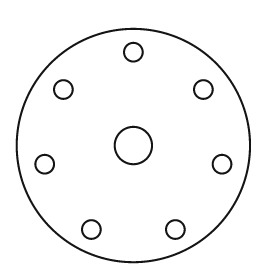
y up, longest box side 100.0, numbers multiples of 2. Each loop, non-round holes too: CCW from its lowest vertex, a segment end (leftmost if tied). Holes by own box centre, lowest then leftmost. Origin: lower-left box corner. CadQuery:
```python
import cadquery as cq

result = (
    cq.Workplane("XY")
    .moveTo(50.0, 50.0)
    .circle(50.0)
    .moveTo(32.0, 14.0)
    .circle(4.0)
    .moveTo(68.0, 14.0)
    .circle(4.0)
    .moveTo(12.0, 42.0)
    .circle(4.0)
    .moveTo(88.0, 42.0)
    .circle(4.0)
    .moveTo(50.0, 50.0)
    .circle(8.0)
    .moveTo(20.0, 74.0)
    .circle(4.0)
    .moveTo(80.0, 74.0)
    .circle(4.0)
    .moveTo(50.0, 90.0)
    .circle(4.0)
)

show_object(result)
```